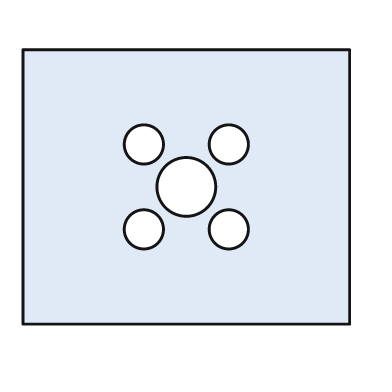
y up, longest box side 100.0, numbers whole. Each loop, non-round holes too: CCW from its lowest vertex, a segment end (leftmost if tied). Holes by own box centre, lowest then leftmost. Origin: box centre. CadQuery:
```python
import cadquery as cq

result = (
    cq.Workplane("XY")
    .moveTo(-50.0, -42.0)
    .lineTo(50.0, -42.0)
    .lineTo(50.0, 42.0)
    .lineTo(-50.0, 42.0)
    .close()
    .moveTo(-13.0, -13.0)
    .circle(6.0)
    .moveTo(13.0, -13.0)
    .circle(6.0)
    .moveTo(0.0, 0.0)
    .circle(9.0)
    .moveTo(-13.0, 13.0)
    .circle(6.0)
    .moveTo(13.0, 13.0)
    .circle(6.0)
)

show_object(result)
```